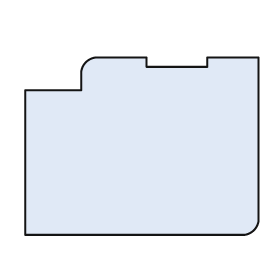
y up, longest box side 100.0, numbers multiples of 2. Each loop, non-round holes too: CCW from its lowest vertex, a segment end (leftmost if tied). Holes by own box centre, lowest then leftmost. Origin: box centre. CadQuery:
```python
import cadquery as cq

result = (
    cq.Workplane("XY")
    .moveTo(-50.0, -38.0)
    .lineTo(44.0, -38.0)
    .threePointArc((48.0, -36.0), (50.0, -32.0))
    .lineTo(50.0, 38.0)
    .lineTo(28.0, 38.0)
    .lineTo(28.0, 34.0)
    .lineTo(2.0, 34.0)
    .lineTo(2.0, 38.0)
    .lineTo(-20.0, 38.0)
    .threePointArc((-24.0, 36.0), (-26.0, 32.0))
    .lineTo(-26.0, 24.0)
    .lineTo(-50.0, 24.0)
    .close()
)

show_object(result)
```